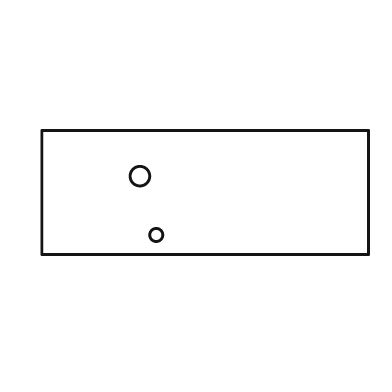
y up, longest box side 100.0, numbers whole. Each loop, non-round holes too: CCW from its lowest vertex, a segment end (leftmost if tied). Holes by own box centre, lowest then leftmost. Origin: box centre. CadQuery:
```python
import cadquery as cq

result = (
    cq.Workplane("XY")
    .moveTo(-50.0, -19.0)
    .lineTo(50.0, -19.0)
    .lineTo(50.0, 19.0)
    .lineTo(-50.0, 19.0)
    .close()
    .moveTo(-15.0, -13.0)
    .circle(2.0)
    .moveTo(-20.0, 5.0)
    .circle(3.0)
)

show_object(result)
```